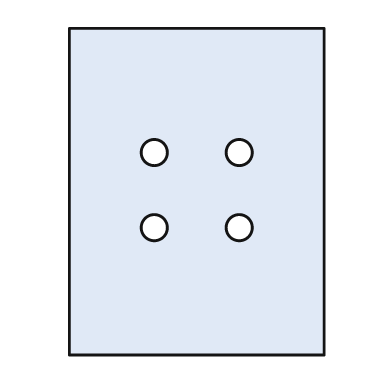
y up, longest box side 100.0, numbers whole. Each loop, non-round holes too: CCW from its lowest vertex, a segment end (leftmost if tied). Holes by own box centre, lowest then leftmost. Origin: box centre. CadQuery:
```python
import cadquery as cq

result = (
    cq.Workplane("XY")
    .moveTo(-39.0, -50.0)
    .lineTo(39.0, -50.0)
    .lineTo(39.0, 50.0)
    .lineTo(-39.0, 50.0)
    .close()
    .moveTo(-13.0, -11.0)
    .circle(4.0)
    .moveTo(13.0, -11.0)
    .circle(4.0)
    .moveTo(-13.0, 12.0)
    .circle(4.0)
    .moveTo(13.0, 12.0)
    .circle(4.0)
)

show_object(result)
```